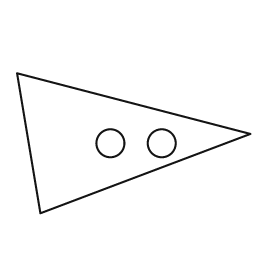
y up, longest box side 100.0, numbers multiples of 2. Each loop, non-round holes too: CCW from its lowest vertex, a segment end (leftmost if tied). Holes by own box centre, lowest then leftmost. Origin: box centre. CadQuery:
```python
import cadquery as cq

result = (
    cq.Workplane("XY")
    .moveTo(-40.0, -30.0)
    .lineTo(50.0, 4.0)
    .lineTo(-50.0, 30.0)
    .close()
    .moveTo(-10.0, 0.0)
    .circle(6.0)
    .moveTo(12.0, 0.0)
    .circle(6.0)
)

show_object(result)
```